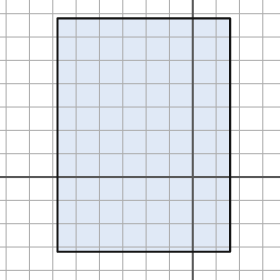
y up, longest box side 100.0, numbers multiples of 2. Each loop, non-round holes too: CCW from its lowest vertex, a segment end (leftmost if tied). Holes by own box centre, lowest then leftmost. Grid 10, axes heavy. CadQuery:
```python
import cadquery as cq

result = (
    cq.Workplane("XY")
    .moveTo(-58.0, -32.0)
    .lineTo(16.0, -32.0)
    .lineTo(16.0, 68.0)
    .lineTo(-58.0, 68.0)
    .close()
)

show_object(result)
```